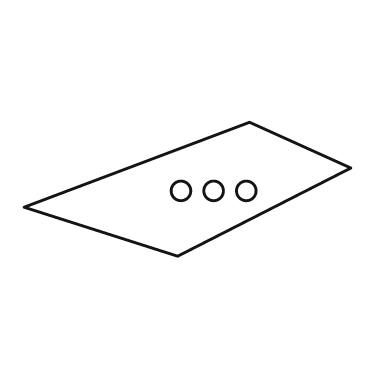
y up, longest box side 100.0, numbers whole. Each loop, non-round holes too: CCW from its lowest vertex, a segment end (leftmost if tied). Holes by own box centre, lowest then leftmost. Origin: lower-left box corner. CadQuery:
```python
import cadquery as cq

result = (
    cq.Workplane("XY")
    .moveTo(47.0, 0.0)
    .lineTo(100.0, 27.0)
    .lineTo(69.0, 41.0)
    .lineTo(0.0, 15.0)
    .close()
    .moveTo(48.0, 20.0)
    .circle(3.0)
    .moveTo(58.0, 20.0)
    .circle(3.0)
    .moveTo(68.0, 20.0)
    .circle(3.0)
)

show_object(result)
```